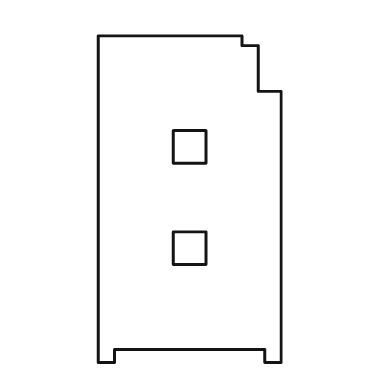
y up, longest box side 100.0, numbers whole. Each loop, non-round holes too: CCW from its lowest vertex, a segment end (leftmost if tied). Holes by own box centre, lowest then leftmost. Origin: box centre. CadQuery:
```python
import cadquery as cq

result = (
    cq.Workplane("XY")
    .moveTo(-28.0, -50.0)
    .lineTo(-23.0, -50.0)
    .lineTo(-23.0, -46.0)
    .lineTo(23.0, -46.0)
    .lineTo(23.0, -50.0)
    .lineTo(28.0, -50.0)
    .lineTo(28.0, 33.0)
    .lineTo(21.0, 33.0)
    .lineTo(21.0, 47.0)
    .lineTo(16.0, 47.0)
    .lineTo(16.0, 50.0)
    .lineTo(-28.0, 50.0)
    .close()
    .moveTo(-5.0, -20.0)
    .lineTo(5.0, -20.0)
    .lineTo(5.0, -10.0)
    .lineTo(-5.0, -10.0)
    .close()
    .moveTo(-5.0, 11.0)
    .lineTo(5.0, 11.0)
    .lineTo(5.0, 21.0)
    .lineTo(-5.0, 21.0)
    .close()
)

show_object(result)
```